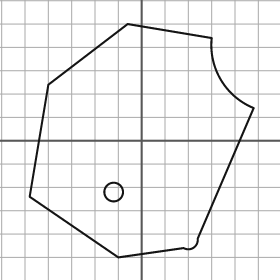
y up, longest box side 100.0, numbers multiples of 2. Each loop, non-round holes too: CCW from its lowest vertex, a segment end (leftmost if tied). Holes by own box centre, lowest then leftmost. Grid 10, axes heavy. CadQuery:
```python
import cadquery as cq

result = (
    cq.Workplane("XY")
    .moveTo(-10.0, -50.0)
    .lineTo(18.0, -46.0)
    .threePointArc((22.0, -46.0), (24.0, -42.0))
    .lineTo(48.0, 14.0)
    .threePointArc((34.0, 26.0), (30.0, 44.0))
    .lineTo(-6.0, 50.0)
    .lineTo(-40.0, 24.0)
    .lineTo(-48.0, -24.0)
    .close()
    .moveTo(-12.0, -22.0)
    .circle(4.0)
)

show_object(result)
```